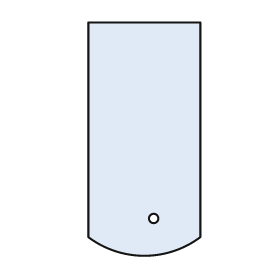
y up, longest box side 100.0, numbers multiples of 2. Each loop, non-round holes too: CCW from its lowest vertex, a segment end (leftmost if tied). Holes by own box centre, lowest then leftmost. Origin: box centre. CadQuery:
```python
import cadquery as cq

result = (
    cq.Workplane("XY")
    .moveTo(-24.0, -42.0)
    .threePointArc((0.0, -50.0), (24.0, -42.0))
    .lineTo(24.0, 50.0)
    .lineTo(-24.0, 50.0)
    .close()
    .moveTo(4.0, -34.0)
    .circle(2.0)
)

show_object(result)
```